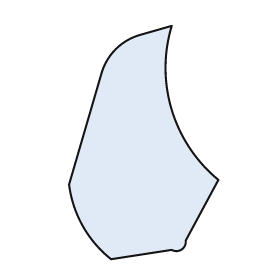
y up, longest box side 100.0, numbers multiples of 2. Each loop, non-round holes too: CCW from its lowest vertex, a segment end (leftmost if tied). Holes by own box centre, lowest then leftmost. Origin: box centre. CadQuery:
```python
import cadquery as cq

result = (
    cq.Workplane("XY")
    .moveTo(-14.0, -50.0)
    .lineTo(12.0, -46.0)
    .threePointArc((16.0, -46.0), (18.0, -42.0))
    .lineTo(32.0, -16.0)
    .threePointArc((12.0, 14.0), (12.0, 50.0))
    .lineTo(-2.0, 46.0)
    .threePointArc((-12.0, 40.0), (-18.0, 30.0))
    .lineTo(-32.0, -18.0)
    .threePointArc((-26.0, -36.0), (-14.0, -50.0))
    .close()
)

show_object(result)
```